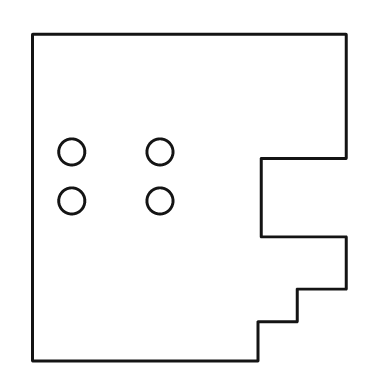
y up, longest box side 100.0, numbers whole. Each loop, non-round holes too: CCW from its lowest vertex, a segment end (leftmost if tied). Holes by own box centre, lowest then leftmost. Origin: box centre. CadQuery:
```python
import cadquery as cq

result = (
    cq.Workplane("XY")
    .moveTo(-48.0, -50.0)
    .lineTo(21.0, -50.0)
    .lineTo(21.0, -38.0)
    .lineTo(33.0, -38.0)
    .lineTo(33.0, -28.0)
    .lineTo(48.0, -28.0)
    .lineTo(48.0, -12.0)
    .lineTo(22.0, -12.0)
    .lineTo(22.0, 12.0)
    .lineTo(48.0, 12.0)
    .lineTo(48.0, 50.0)
    .lineTo(-48.0, 50.0)
    .close()
    .moveTo(-36.0, -1.0)
    .circle(4.0)
    .moveTo(-9.0, -1.0)
    .circle(4.0)
    .moveTo(-36.0, 14.0)
    .circle(4.0)
    .moveTo(-9.0, 14.0)
    .circle(4.0)
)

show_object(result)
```